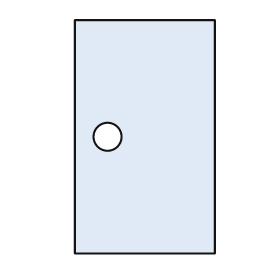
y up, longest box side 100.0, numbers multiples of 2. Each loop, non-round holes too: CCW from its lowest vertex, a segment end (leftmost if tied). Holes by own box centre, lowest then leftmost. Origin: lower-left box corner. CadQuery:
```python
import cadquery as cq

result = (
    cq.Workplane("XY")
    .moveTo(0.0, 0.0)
    .lineTo(60.0, 0.0)
    .lineTo(60.0, 100.0)
    .lineTo(0.0, 100.0)
    .close()
    .moveTo(14.0, 50.0)
    .circle(6.0)
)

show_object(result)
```